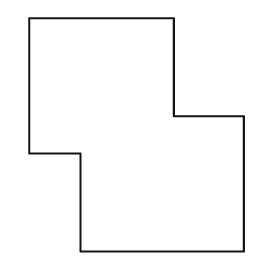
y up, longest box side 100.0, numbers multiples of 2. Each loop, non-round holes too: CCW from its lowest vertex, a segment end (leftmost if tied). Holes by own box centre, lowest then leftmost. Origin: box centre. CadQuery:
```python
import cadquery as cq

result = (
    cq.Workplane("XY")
    .moveTo(-24.0, -50.0)
    .lineTo(46.0, -50.0)
    .lineTo(46.0, 8.0)
    .lineTo(16.0, 8.0)
    .lineTo(16.0, 50.0)
    .lineTo(-46.0, 50.0)
    .lineTo(-46.0, -8.0)
    .lineTo(-24.0, -8.0)
    .close()
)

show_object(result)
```